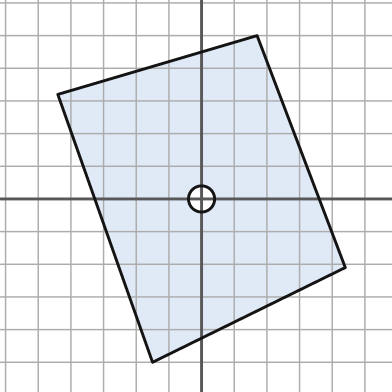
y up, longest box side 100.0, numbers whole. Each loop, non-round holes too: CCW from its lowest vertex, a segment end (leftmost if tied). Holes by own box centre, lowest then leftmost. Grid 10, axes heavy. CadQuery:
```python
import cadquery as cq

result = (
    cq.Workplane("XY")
    .moveTo(-15.0, -50.0)
    .lineTo(44.0, -21.0)
    .lineTo(17.0, 50.0)
    .lineTo(-44.0, 32.0)
    .close()
    .moveTo(0.0, 0.0)
    .circle(4.0)
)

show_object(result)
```